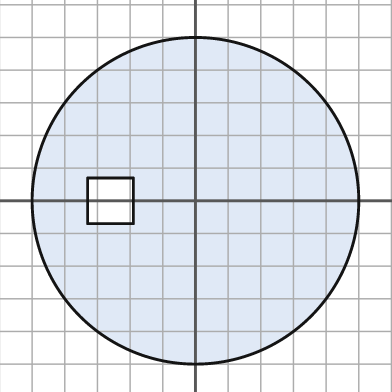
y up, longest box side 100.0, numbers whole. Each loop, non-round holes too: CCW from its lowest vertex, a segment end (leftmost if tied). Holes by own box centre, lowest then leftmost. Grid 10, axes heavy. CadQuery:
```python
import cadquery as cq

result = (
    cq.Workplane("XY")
    .moveTo(0.0, 0.0)
    .circle(50.0)
    .moveTo(-33.0, -7.0)
    .lineTo(-19.0, -7.0)
    .lineTo(-19.0, 7.0)
    .lineTo(-33.0, 7.0)
    .close()
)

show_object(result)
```